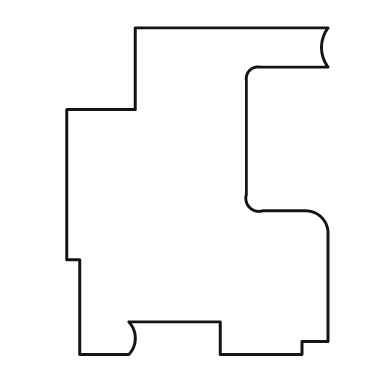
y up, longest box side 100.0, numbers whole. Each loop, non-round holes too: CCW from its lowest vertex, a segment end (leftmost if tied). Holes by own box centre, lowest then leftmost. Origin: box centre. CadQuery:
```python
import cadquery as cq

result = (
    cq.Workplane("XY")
    .moveTo(-36.0, -50.0)
    .lineTo(-21.0, -50.0)
    .threePointArc((-19.0, -45.0), (-21.0, -40.0))
    .lineTo(7.0, -40.0)
    .lineTo(7.0, -50.0)
    .lineTo(32.0, -50.0)
    .lineTo(32.0, -46.0)
    .lineTo(40.0, -46.0)
    .lineTo(40.0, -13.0)
    .threePointArc((38.0, -8.0), (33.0, -6.0))
    .lineTo(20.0, -6.0)
    .threePointArc((16.0, -5.0), (15.0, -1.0))
    .lineTo(15.0, 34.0)
    .threePointArc((16.0, 37.0), (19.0, 38.0))
    .lineTo(40.0, 38.0)
    .threePointArc((38.0, 44.0), (40.0, 50.0))
    .lineTo(-19.0, 50.0)
    .lineTo(-19.0, 25.0)
    .lineTo(-40.0, 25.0)
    .lineTo(-40.0, -21.0)
    .lineTo(-36.0, -21.0)
    .close()
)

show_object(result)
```